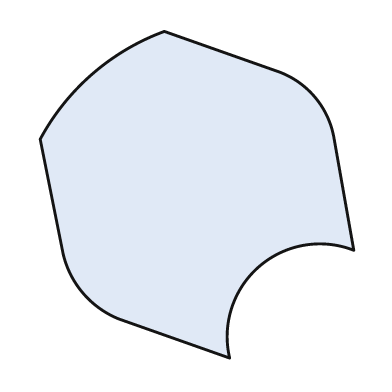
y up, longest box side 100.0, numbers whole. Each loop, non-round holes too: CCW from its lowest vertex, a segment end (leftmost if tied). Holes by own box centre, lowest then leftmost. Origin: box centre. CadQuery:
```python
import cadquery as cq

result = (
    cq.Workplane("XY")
    .moveTo(10.0, -50.0)
    .threePointArc((19.0, -22.0), (48.0, -17.0))
    .lineTo(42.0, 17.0)
    .threePointArc((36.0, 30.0), (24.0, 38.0))
    .lineTo(-10.0, 50.0)
    .threePointArc((-32.0, 37.0), (-48.0, 17.0))
    .lineTo(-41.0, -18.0)
    .threePointArc((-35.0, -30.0), (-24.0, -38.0))
    .close()
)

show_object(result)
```